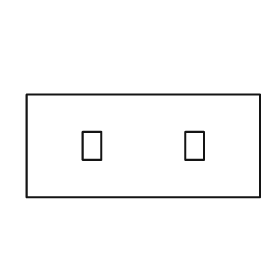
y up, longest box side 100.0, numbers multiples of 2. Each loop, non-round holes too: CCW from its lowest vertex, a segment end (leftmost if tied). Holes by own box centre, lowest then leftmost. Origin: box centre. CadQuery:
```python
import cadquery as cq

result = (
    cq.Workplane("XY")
    .moveTo(-50.0, -22.0)
    .lineTo(50.0, -22.0)
    .lineTo(50.0, 22.0)
    .lineTo(-50.0, 22.0)
    .close()
    .moveTo(-26.0, -6.0)
    .lineTo(-18.0, -6.0)
    .lineTo(-18.0, 6.0)
    .lineTo(-26.0, 6.0)
    .close()
    .moveTo(18.0, -6.0)
    .lineTo(26.0, -6.0)
    .lineTo(26.0, 6.0)
    .lineTo(18.0, 6.0)
    .close()
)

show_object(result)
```